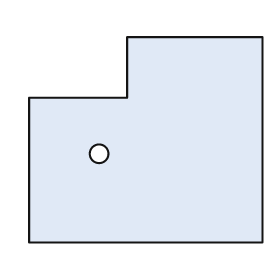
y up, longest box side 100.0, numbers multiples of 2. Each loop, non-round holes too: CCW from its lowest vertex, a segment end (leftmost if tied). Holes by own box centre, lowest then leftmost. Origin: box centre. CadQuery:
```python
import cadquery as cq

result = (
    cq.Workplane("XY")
    .moveTo(-50.0, -44.0)
    .lineTo(50.0, -44.0)
    .lineTo(50.0, 44.0)
    .lineTo(-8.0, 44.0)
    .lineTo(-8.0, 18.0)
    .lineTo(-50.0, 18.0)
    .close()
    .moveTo(-20.0, -6.0)
    .circle(4.0)
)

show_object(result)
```